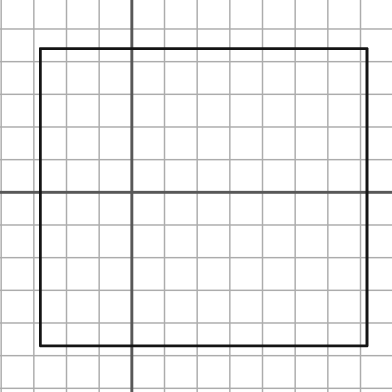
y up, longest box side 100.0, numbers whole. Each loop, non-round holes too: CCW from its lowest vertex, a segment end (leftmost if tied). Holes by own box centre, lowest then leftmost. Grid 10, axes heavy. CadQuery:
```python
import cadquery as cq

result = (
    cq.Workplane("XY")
    .moveTo(-28.0, -47.0)
    .lineTo(72.0, -47.0)
    .lineTo(72.0, 44.0)
    .lineTo(-28.0, 44.0)
    .close()
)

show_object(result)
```